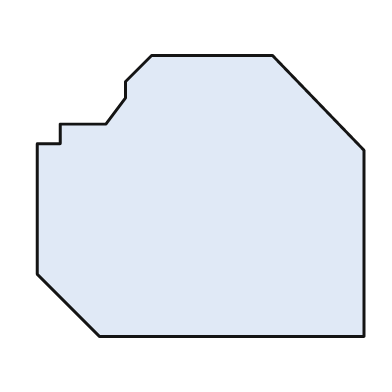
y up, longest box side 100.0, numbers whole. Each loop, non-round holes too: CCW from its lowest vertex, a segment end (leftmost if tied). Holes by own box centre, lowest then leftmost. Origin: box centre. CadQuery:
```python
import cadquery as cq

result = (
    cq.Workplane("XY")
    .moveTo(-31.0, -43.0)
    .lineTo(50.0, -43.0)
    .lineTo(50.0, 14.0)
    .lineTo(22.0, 43.0)
    .lineTo(-15.0, 43.0)
    .lineTo(-23.0, 35.0)
    .lineTo(-23.0, 30.0)
    .lineTo(-29.0, 22.0)
    .lineTo(-43.0, 22.0)
    .lineTo(-43.0, 16.0)
    .lineTo(-50.0, 16.0)
    .lineTo(-50.0, -24.0)
    .close()
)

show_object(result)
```